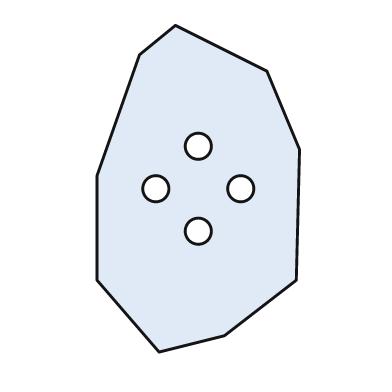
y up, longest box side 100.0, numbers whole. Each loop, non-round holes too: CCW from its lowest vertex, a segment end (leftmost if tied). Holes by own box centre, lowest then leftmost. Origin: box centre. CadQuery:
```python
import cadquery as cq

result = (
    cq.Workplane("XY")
    .moveTo(-12.0, -50.0)
    .lineTo(8.0, -45.0)
    .lineTo(30.0, -28.0)
    .lineTo(31.0, 12.0)
    .lineTo(21.0, 36.0)
    .lineTo(-7.0, 50.0)
    .lineTo(-18.0, 41.0)
    .lineTo(-31.0, 4.0)
    .lineTo(-31.0, -28.0)
    .close()
    .moveTo(0.0, -13.0)
    .circle(4.0)
    .moveTo(-13.0, 0.0)
    .circle(4.0)
    .moveTo(13.0, 0.0)
    .circle(4.0)
    .moveTo(0.0, 13.0)
    .circle(4.0)
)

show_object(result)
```